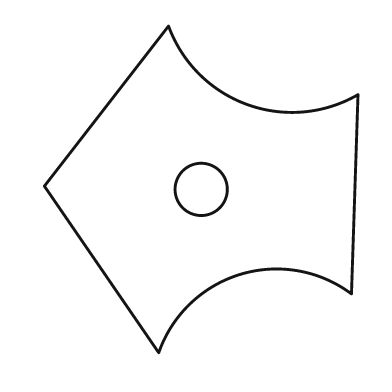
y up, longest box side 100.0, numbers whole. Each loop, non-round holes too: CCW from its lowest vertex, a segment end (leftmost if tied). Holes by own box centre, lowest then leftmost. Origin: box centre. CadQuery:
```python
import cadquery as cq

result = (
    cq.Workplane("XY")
    .moveTo(-13.0, -50.0)
    .threePointArc((12.0, -26.0), (46.0, -32.0))
    .lineTo(48.0, 29.0)
    .threePointArc((14.0, 26.0), (-10.0, 50.0))
    .lineTo(-48.0, 1.0)
    .close()
    .moveTo(0.0, 0.0)
    .circle(8.0)
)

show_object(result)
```